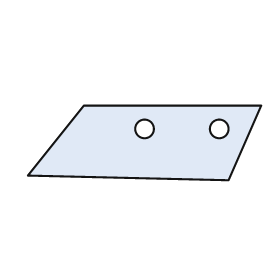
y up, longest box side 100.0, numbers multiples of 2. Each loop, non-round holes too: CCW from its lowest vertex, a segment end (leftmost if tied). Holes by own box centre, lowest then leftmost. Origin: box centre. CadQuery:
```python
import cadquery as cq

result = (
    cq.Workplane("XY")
    .moveTo(36.0, -16.0)
    .lineTo(50.0, 16.0)
    .lineTo(-26.0, 16.0)
    .lineTo(-50.0, -14.0)
    .close()
    .moveTo(0.0, 6.0)
    .circle(4.0)
    .moveTo(32.0, 6.0)
    .circle(4.0)
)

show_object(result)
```